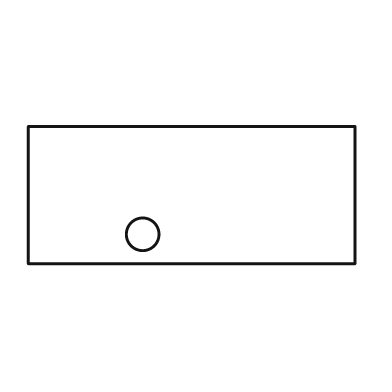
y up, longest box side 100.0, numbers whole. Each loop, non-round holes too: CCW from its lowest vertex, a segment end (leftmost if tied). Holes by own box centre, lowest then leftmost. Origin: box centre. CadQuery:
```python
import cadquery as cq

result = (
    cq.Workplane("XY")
    .moveTo(-50.0, -21.0)
    .lineTo(50.0, -21.0)
    .lineTo(50.0, 21.0)
    .lineTo(-50.0, 21.0)
    .close()
    .moveTo(-15.0, -12.0)
    .circle(5.0)
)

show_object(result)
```